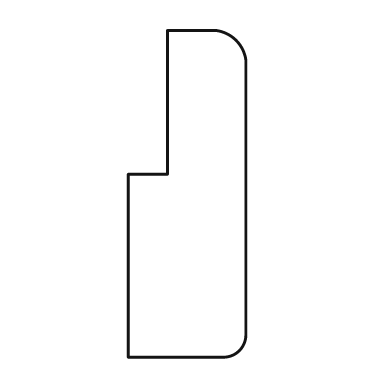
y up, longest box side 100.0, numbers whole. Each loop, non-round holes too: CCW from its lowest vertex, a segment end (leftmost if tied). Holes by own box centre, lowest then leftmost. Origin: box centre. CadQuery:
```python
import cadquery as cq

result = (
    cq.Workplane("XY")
    .moveTo(-18.0, -50.0)
    .lineTo(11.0, -50.0)
    .threePointArc((16.0, -48.0), (18.0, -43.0))
    .lineTo(18.0, 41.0)
    .threePointArc((15.0, 47.0), (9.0, 50.0))
    .lineTo(-6.0, 50.0)
    .lineTo(-6.0, 6.0)
    .lineTo(-18.0, 6.0)
    .close()
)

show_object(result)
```